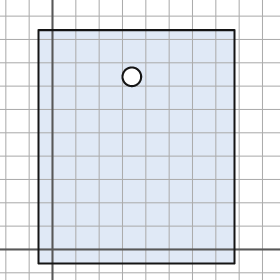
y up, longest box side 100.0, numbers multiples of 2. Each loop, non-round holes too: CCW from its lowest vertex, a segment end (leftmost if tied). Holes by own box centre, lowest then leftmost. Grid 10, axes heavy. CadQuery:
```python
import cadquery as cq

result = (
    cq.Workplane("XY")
    .moveTo(-6.0, -6.0)
    .lineTo(78.0, -6.0)
    .lineTo(78.0, 94.0)
    .lineTo(-6.0, 94.0)
    .close()
    .moveTo(34.0, 74.0)
    .circle(4.0)
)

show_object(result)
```